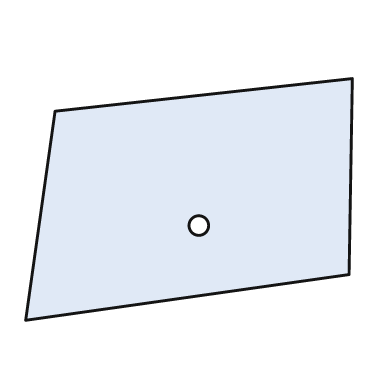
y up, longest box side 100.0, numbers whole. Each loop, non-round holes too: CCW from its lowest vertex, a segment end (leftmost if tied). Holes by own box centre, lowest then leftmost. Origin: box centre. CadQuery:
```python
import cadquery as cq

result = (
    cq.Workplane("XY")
    .moveTo(-50.0, -37.0)
    .lineTo(49.0, -23.0)
    .lineTo(50.0, 37.0)
    .lineTo(-41.0, 27.0)
    .close()
    .moveTo(3.0, -8.0)
    .circle(3.0)
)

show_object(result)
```